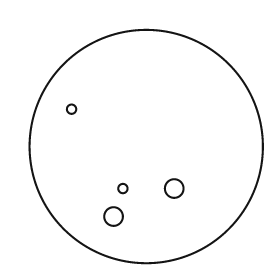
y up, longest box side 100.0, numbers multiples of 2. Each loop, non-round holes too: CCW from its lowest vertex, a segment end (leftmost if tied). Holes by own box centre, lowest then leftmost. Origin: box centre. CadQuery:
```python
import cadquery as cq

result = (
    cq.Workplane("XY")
    .moveTo(0.0, 0.0)
    .circle(50.0)
    .moveTo(-14.0, -30.0)
    .circle(4.0)
    .moveTo(-10.0, -18.0)
    .circle(2.0)
    .moveTo(12.0, -18.0)
    .circle(4.0)
    .moveTo(-32.0, 16.0)
    .circle(2.0)
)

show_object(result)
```